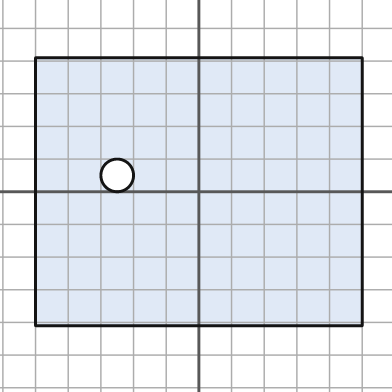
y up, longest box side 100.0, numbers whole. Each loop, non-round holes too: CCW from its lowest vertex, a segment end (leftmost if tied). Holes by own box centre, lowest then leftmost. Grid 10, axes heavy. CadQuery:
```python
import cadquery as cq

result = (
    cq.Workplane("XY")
    .moveTo(-50.0, -41.0)
    .lineTo(50.0, -41.0)
    .lineTo(50.0, 41.0)
    .lineTo(-50.0, 41.0)
    .close()
    .moveTo(-25.0, 5.0)
    .circle(5.0)
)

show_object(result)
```